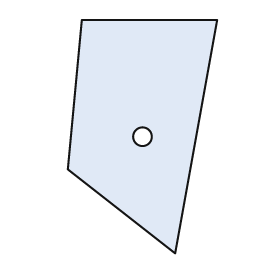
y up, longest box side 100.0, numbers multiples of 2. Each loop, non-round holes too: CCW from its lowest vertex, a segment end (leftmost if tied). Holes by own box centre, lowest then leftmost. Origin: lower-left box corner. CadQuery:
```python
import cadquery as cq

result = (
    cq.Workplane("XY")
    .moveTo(46.0, 0.0)
    .lineTo(64.0, 100.0)
    .lineTo(6.0, 100.0)
    .lineTo(0.0, 36.0)
    .close()
    .moveTo(32.0, 50.0)
    .circle(4.0)
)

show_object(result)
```